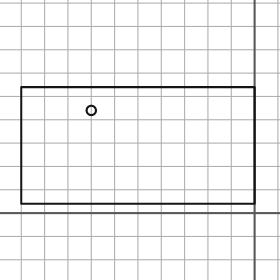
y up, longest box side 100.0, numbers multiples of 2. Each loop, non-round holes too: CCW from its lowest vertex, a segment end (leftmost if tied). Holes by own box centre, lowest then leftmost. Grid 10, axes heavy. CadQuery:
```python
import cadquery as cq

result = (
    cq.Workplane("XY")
    .moveTo(-100.0, 4.0)
    .lineTo(0.0, 4.0)
    .lineTo(0.0, 54.0)
    .lineTo(-100.0, 54.0)
    .close()
    .moveTo(-70.0, 44.0)
    .circle(2.0)
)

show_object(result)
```